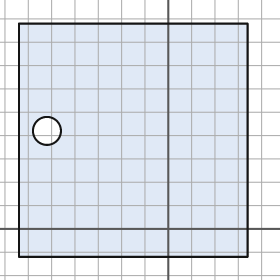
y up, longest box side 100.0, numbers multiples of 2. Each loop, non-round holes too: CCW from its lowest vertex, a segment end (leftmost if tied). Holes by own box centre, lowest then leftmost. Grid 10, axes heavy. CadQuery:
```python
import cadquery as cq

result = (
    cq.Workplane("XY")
    .moveTo(-64.0, -12.0)
    .lineTo(34.0, -12.0)
    .lineTo(34.0, 88.0)
    .lineTo(-64.0, 88.0)
    .close()
    .moveTo(-52.0, 42.0)
    .circle(6.0)
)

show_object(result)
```